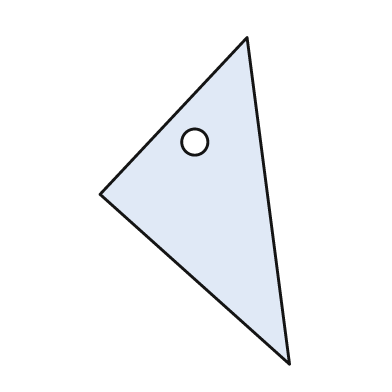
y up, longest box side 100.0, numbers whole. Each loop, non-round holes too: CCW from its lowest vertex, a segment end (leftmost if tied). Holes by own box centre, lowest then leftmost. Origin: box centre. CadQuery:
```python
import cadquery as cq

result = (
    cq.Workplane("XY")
    .moveTo(29.0, -50.0)
    .lineTo(16.0, 50.0)
    .lineTo(-29.0, 2.0)
    .close()
    .moveTo(0.0, 18.0)
    .circle(4.0)
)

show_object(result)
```